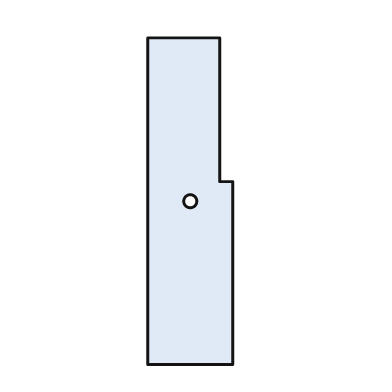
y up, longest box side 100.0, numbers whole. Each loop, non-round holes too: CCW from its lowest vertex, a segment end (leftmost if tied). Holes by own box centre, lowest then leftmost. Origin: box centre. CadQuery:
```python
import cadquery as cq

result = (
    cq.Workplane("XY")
    .moveTo(-13.0, -50.0)
    .lineTo(13.0, -50.0)
    .lineTo(13.0, 6.0)
    .lineTo(9.0, 6.0)
    .lineTo(9.0, 50.0)
    .lineTo(-13.0, 50.0)
    .close()
    .moveTo(0.0, 0.0)
    .circle(2.0)
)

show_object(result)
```